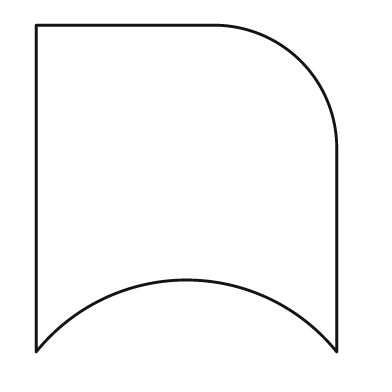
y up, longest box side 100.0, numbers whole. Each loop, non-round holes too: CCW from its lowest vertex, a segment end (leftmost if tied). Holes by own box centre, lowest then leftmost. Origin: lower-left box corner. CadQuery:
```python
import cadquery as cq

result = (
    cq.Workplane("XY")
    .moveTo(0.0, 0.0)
    .threePointArc((46.0, 22.0), (92.0, 0.0))
    .lineTo(92.0, 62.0)
    .threePointArc((81.0, 89.0), (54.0, 100.0))
    .lineTo(0.0, 100.0)
    .close()
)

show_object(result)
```